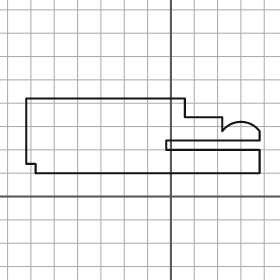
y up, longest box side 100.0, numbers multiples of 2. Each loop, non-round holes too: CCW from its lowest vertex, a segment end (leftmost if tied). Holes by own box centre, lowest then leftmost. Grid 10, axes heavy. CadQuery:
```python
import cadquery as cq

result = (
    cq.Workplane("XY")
    .moveTo(-58.0, 10.0)
    .lineTo(38.0, 10.0)
    .lineTo(38.0, 20.0)
    .lineTo(-2.0, 20.0)
    .lineTo(-2.0, 24.0)
    .lineTo(38.0, 24.0)
    .lineTo(38.0, 28.0)
    .threePointArc((30.0, 32.0), (22.0, 28.0))
    .lineTo(22.0, 34.0)
    .lineTo(6.0, 34.0)
    .lineTo(6.0, 42.0)
    .lineTo(-62.0, 42.0)
    .lineTo(-62.0, 14.0)
    .lineTo(-58.0, 14.0)
    .close()
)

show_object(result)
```